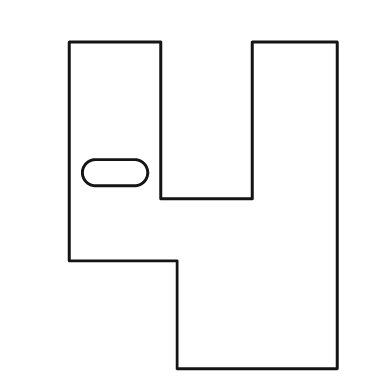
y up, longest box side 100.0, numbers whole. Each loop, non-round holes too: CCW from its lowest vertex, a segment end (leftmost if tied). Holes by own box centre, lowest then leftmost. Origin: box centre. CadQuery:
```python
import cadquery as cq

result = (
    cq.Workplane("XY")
    .moveTo(-8.0, -50.0)
    .lineTo(41.0, -50.0)
    .lineTo(41.0, 50.0)
    .lineTo(15.0, 50.0)
    .lineTo(15.0, 2.0)
    .lineTo(-13.0, 2.0)
    .lineTo(-13.0, 50.0)
    .lineTo(-41.0, 50.0)
    .lineTo(-41.0, -17.0)
    .lineTo(-8.0, -17.0)
    .close()
    .moveTo(-33.0, 6.0)
    .lineTo(-21.0, 6.0)
    .threePointArc((-17.0, 10.0), (-21.0, 14.0))
    .lineTo(-33.0, 14.0)
    .threePointArc((-37.0, 10.0), (-33.0, 6.0))
    .close()
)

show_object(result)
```